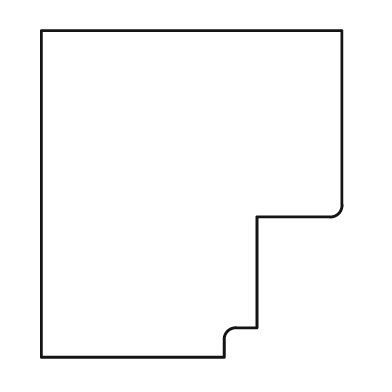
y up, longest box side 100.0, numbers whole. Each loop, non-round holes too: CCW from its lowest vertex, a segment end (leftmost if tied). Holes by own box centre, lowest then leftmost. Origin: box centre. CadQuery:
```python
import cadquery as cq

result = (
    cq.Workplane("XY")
    .moveTo(-46.0, -50.0)
    .lineTo(10.0, -50.0)
    .lineTo(10.0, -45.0)
    .threePointArc((11.0, -42.0), (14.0, -41.0))
    .lineTo(20.0, -41.0)
    .lineTo(20.0, -7.0)
    .lineTo(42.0, -7.0)
    .threePointArc((45.0, -6.0), (46.0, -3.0))
    .lineTo(46.0, 50.0)
    .lineTo(-46.0, 50.0)
    .close()
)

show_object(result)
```